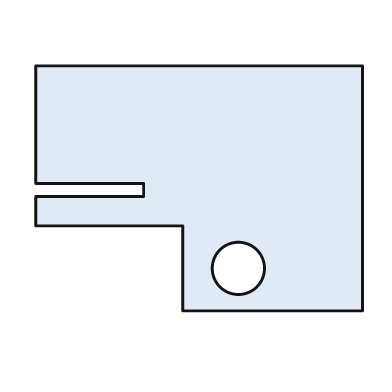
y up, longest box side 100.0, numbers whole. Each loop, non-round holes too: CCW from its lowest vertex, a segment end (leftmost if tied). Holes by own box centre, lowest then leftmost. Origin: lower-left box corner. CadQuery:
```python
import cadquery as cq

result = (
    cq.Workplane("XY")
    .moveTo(45.0, 0.0)
    .lineTo(100.0, 0.0)
    .lineTo(100.0, 75.0)
    .lineTo(0.0, 75.0)
    .lineTo(0.0, 39.0)
    .lineTo(33.0, 39.0)
    .lineTo(33.0, 35.0)
    .lineTo(0.0, 35.0)
    .lineTo(0.0, 26.0)
    .lineTo(45.0, 26.0)
    .close()
    .moveTo(62.0, 13.0)
    .circle(8.0)
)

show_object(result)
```